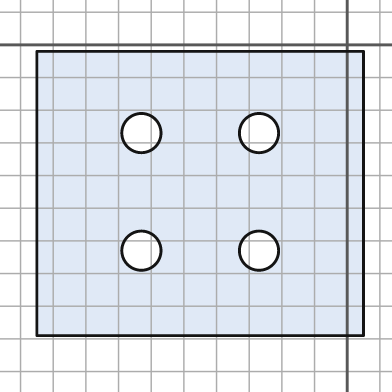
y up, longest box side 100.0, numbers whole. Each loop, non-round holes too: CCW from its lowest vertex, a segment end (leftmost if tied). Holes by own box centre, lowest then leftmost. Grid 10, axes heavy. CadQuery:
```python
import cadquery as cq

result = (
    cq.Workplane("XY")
    .moveTo(-95.0, -89.0)
    .lineTo(5.0, -89.0)
    .lineTo(5.0, -2.0)
    .lineTo(-95.0, -2.0)
    .close()
    .moveTo(-63.0, -63.0)
    .circle(6.0)
    .moveTo(-27.0, -63.0)
    .circle(6.0)
    .moveTo(-63.0, -27.0)
    .circle(6.0)
    .moveTo(-27.0, -27.0)
    .circle(6.0)
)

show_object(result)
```